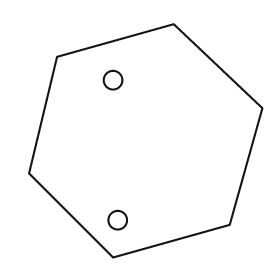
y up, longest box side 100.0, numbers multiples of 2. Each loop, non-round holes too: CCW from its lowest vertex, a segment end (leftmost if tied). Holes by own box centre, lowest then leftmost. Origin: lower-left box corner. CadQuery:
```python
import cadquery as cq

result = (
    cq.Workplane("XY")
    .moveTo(36.0, 0.0)
    .lineTo(86.0, 14.0)
    .lineTo(100.0, 64.0)
    .lineTo(62.0, 100.0)
    .lineTo(12.0, 86.0)
    .lineTo(0.0, 36.0)
    .close()
    .moveTo(38.0, 16.0)
    .circle(4.0)
    .moveTo(36.0, 76.0)
    .circle(4.0)
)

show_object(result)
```